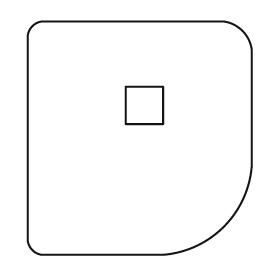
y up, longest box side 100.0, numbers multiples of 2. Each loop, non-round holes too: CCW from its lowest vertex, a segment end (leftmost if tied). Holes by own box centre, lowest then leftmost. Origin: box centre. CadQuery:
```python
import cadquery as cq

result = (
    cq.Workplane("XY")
    .moveTo(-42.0, -50.0)
    .lineTo(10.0, -50.0)
    .threePointArc((36.0, -38.0), (48.0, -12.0))
    .lineTo(48.0, 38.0)
    .threePointArc((44.0, 46.0), (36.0, 50.0))
    .lineTo(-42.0, 50.0)
    .threePointArc((-46.0, 48.0), (-48.0, 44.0))
    .lineTo(-48.0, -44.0)
    .threePointArc((-46.0, -48.0), (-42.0, -50.0))
    .close()
    .moveTo(-6.0, 6.0)
    .lineTo(10.0, 6.0)
    .lineTo(10.0, 22.0)
    .lineTo(-6.0, 22.0)
    .close()
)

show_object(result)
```